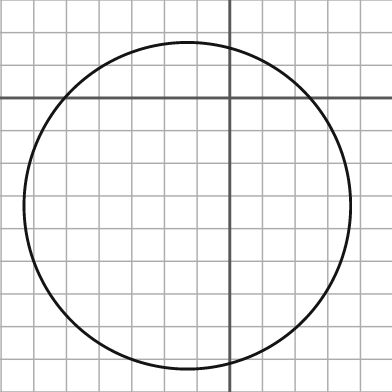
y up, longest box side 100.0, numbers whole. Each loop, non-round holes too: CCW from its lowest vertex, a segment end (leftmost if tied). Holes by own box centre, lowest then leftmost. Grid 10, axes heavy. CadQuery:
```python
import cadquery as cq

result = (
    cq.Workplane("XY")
    .moveTo(-13.0, -33.0)
    .circle(50.0)
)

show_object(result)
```